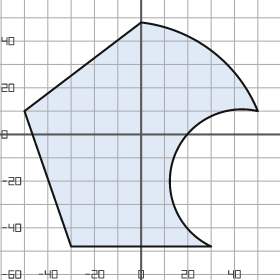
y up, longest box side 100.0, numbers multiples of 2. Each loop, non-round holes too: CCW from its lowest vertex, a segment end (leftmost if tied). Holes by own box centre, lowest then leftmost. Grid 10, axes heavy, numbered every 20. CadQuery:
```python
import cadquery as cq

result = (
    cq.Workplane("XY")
    .moveTo(-30.0, -48.0)
    .lineTo(30.0, -48.0)
    .threePointArc((14.0, -10.0), (50.0, 10.0))
    .threePointArc((30.0, 36.0), (0.0, 48.0))
    .lineTo(-50.0, 10.0)
    .close()
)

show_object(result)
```